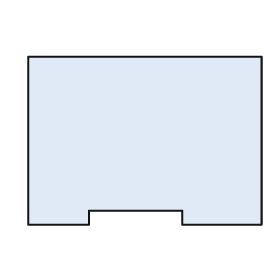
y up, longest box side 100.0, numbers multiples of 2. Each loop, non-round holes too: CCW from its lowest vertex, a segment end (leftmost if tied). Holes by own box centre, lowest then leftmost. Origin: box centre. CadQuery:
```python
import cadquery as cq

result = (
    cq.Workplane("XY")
    .moveTo(-50.0, -36.0)
    .lineTo(-24.0, -36.0)
    .lineTo(-24.0, -30.0)
    .lineTo(16.0, -30.0)
    .lineTo(16.0, -36.0)
    .lineTo(50.0, -36.0)
    .lineTo(50.0, 36.0)
    .lineTo(-50.0, 36.0)
    .close()
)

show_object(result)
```